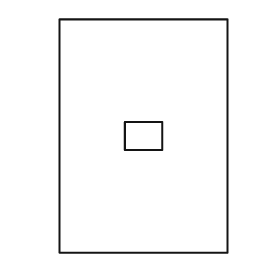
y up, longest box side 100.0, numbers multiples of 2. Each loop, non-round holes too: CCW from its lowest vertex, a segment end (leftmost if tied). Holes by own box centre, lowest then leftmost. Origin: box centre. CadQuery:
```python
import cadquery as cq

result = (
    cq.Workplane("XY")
    .moveTo(-36.0, -50.0)
    .lineTo(36.0, -50.0)
    .lineTo(36.0, 50.0)
    .lineTo(-36.0, 50.0)
    .close()
    .moveTo(-8.0, -6.0)
    .lineTo(8.0, -6.0)
    .lineTo(8.0, 6.0)
    .lineTo(-8.0, 6.0)
    .close()
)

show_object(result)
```